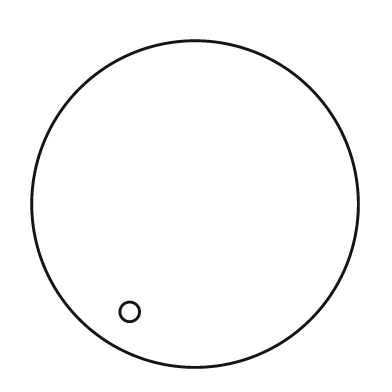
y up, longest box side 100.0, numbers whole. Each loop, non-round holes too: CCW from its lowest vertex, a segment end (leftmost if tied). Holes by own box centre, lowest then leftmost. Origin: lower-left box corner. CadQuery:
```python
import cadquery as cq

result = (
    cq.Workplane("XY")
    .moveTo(50.0, 50.0)
    .circle(50.0)
    .moveTo(30.0, 17.0)
    .circle(3.0)
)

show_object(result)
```